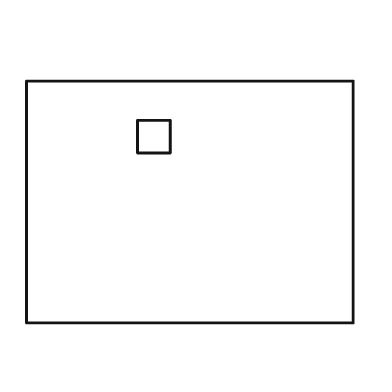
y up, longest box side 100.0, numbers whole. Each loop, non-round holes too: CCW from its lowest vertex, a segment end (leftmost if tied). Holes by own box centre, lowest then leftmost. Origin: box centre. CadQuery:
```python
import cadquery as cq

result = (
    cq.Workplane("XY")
    .moveTo(-50.0, -37.0)
    .lineTo(50.0, -37.0)
    .lineTo(50.0, 37.0)
    .lineTo(-50.0, 37.0)
    .close()
    .moveTo(-16.0, 15.0)
    .lineTo(-6.0, 15.0)
    .lineTo(-6.0, 25.0)
    .lineTo(-16.0, 25.0)
    .close()
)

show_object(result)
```